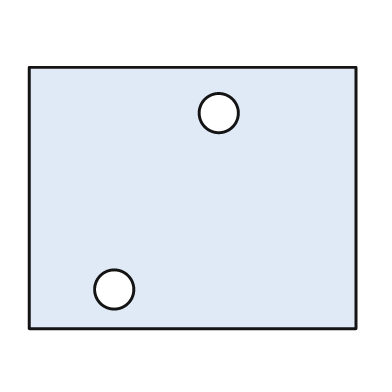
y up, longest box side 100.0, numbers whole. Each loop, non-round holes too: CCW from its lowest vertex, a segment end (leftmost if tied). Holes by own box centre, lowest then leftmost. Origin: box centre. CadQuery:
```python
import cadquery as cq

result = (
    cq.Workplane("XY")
    .moveTo(-50.0, -40.0)
    .lineTo(50.0, -40.0)
    .lineTo(50.0, 40.0)
    .lineTo(-50.0, 40.0)
    .close()
    .moveTo(-24.0, -28.0)
    .circle(6.0)
    .moveTo(8.0, 26.0)
    .circle(6.0)
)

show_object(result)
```